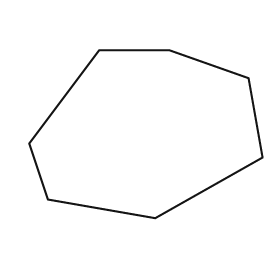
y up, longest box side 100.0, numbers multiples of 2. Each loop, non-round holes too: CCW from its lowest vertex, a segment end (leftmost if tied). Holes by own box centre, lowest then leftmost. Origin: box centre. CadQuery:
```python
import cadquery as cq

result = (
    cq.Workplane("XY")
    .moveTo(4.0, -36.0)
    .lineTo(50.0, -10.0)
    .lineTo(44.0, 24.0)
    .lineTo(10.0, 36.0)
    .lineTo(-20.0, 36.0)
    .lineTo(-50.0, -4.0)
    .lineTo(-42.0, -28.0)
    .close()
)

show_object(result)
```